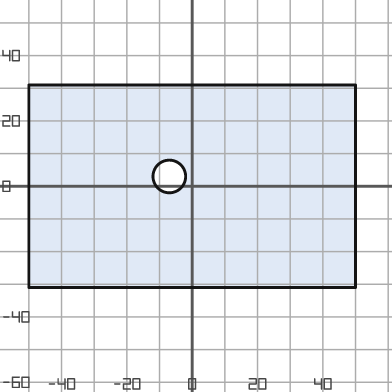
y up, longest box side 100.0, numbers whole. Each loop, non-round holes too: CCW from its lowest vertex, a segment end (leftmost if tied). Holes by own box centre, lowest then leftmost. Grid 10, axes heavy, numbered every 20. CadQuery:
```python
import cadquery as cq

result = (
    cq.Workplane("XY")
    .moveTo(-50.0, -31.0)
    .lineTo(50.0, -31.0)
    .lineTo(50.0, 31.0)
    .lineTo(-50.0, 31.0)
    .close()
    .moveTo(-7.0, 3.0)
    .circle(5.0)
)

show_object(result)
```